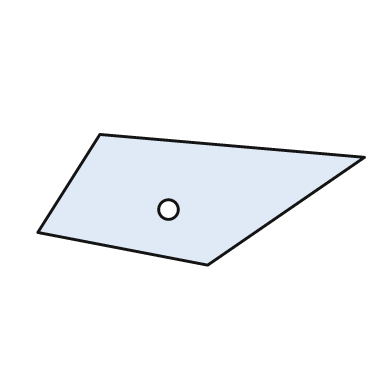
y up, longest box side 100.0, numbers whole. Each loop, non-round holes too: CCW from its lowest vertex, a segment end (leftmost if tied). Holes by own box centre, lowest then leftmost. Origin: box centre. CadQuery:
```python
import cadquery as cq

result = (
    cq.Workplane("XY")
    .moveTo(2.0, -20.0)
    .lineTo(50.0, 13.0)
    .lineTo(-31.0, 20.0)
    .lineTo(-50.0, -10.0)
    .close()
    .moveTo(-10.0, -3.0)
    .circle(3.0)
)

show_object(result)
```